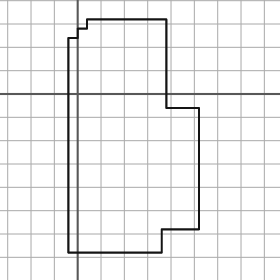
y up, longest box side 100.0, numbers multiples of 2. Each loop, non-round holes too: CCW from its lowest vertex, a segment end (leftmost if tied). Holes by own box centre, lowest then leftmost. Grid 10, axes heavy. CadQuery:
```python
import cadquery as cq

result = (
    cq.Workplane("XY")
    .moveTo(-4.0, -68.0)
    .lineTo(36.0, -68.0)
    .lineTo(36.0, -58.0)
    .lineTo(52.0, -58.0)
    .lineTo(52.0, -6.0)
    .lineTo(38.0, -6.0)
    .lineTo(38.0, 32.0)
    .lineTo(4.0, 32.0)
    .lineTo(4.0, 28.0)
    .lineTo(0.0, 28.0)
    .lineTo(0.0, 24.0)
    .lineTo(-4.0, 24.0)
    .close()
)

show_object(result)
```